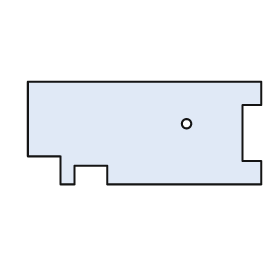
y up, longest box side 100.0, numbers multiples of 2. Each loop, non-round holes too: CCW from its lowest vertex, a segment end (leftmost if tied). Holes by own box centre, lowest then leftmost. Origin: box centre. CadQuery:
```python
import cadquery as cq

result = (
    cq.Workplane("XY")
    .moveTo(-36.0, -22.0)
    .lineTo(-30.0, -22.0)
    .lineTo(-30.0, -14.0)
    .lineTo(-16.0, -14.0)
    .lineTo(-16.0, -22.0)
    .lineTo(50.0, -22.0)
    .lineTo(50.0, -12.0)
    .lineTo(42.0, -12.0)
    .lineTo(42.0, 12.0)
    .lineTo(50.0, 12.0)
    .lineTo(50.0, 22.0)
    .lineTo(-50.0, 22.0)
    .lineTo(-50.0, -10.0)
    .lineTo(-36.0, -10.0)
    .close()
    .moveTo(18.0, 4.0)
    .circle(2.0)
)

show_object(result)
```